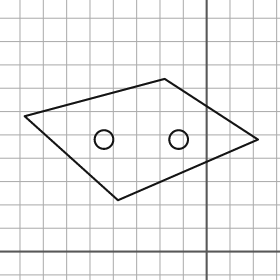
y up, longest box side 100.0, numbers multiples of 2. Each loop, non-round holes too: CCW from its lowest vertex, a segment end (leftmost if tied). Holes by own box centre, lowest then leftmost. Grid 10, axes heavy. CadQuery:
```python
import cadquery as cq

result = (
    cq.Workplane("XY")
    .moveTo(-38.0, 22.0)
    .lineTo(22.0, 48.0)
    .lineTo(-18.0, 74.0)
    .lineTo(-78.0, 58.0)
    .close()
    .moveTo(-44.0, 48.0)
    .circle(4.0)
    .moveTo(-12.0, 48.0)
    .circle(4.0)
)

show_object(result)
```